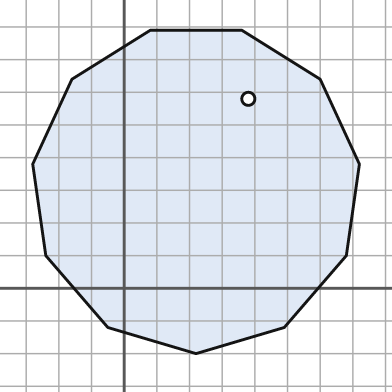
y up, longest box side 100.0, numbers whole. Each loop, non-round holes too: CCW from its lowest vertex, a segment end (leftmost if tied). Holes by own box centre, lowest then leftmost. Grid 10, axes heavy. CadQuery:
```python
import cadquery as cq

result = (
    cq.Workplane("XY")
    .moveTo(22.0, -20.0)
    .lineTo(49.0, -12.0)
    .lineTo(68.0, 10.0)
    .lineTo(72.0, 38.0)
    .lineTo(60.0, 64.0)
    .lineTo(36.0, 79.0)
    .lineTo(8.0, 79.0)
    .lineTo(-16.0, 64.0)
    .lineTo(-28.0, 38.0)
    .lineTo(-24.0, 10.0)
    .lineTo(-5.0, -12.0)
    .close()
    .moveTo(38.0, 58.0)
    .circle(2.0)
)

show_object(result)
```